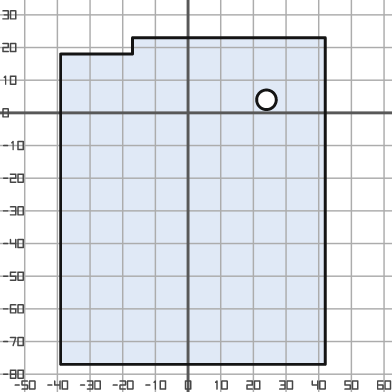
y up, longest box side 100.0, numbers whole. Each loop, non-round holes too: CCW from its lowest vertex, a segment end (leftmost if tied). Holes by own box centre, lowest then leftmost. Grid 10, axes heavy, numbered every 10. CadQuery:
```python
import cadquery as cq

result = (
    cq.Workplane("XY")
    .moveTo(-39.0, -77.0)
    .lineTo(42.0, -77.0)
    .lineTo(42.0, 23.0)
    .lineTo(-17.0, 23.0)
    .lineTo(-17.0, 18.0)
    .lineTo(-39.0, 18.0)
    .close()
    .moveTo(24.0, 4.0)
    .circle(3.0)
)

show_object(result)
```